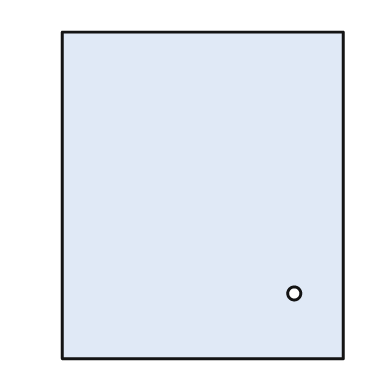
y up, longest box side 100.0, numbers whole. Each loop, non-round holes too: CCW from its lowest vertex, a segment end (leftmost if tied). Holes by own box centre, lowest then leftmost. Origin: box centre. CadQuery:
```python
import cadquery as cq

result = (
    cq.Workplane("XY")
    .moveTo(-43.0, -50.0)
    .lineTo(43.0, -50.0)
    .lineTo(43.0, 50.0)
    .lineTo(-43.0, 50.0)
    .close()
    .moveTo(28.0, -30.0)
    .circle(2.0)
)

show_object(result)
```